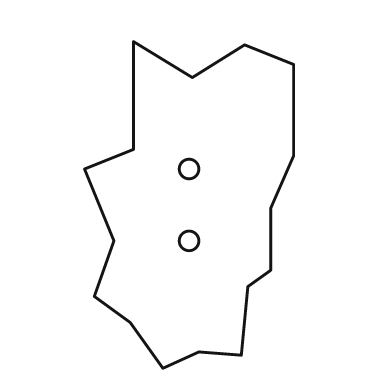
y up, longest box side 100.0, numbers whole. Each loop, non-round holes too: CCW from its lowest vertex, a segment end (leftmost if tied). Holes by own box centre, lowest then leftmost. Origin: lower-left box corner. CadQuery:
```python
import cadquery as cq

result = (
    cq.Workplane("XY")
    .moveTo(24.0, 0.0)
    .lineTo(35.0, 5.0)
    .lineTo(48.0, 4.0)
    .lineTo(50.0, 25.0)
    .lineTo(57.0, 30.0)
    .lineTo(57.0, 49.0)
    .lineTo(64.0, 65.0)
    .lineTo(64.0, 93.0)
    .lineTo(49.0, 99.0)
    .lineTo(33.0, 89.0)
    .lineTo(15.0, 100.0)
    .lineTo(15.0, 67.0)
    .lineTo(0.0, 61.0)
    .lineTo(9.0, 39.0)
    .lineTo(3.0, 22.0)
    .lineTo(14.0, 14.0)
    .close()
    .moveTo(32.0, 39.0)
    .circle(3.0)
    .moveTo(32.0, 61.0)
    .circle(3.0)
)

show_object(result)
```